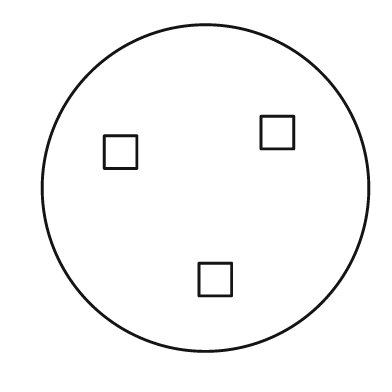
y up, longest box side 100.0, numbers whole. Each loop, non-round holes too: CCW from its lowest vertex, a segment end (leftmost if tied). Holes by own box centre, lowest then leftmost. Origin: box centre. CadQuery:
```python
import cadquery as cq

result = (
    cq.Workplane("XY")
    .moveTo(0.0, 0.0)
    .circle(50.0)
    .moveTo(-2.0, -33.0)
    .lineTo(8.0, -33.0)
    .lineTo(8.0, -23.0)
    .lineTo(-2.0, -23.0)
    .close()
    .moveTo(-31.0, 6.0)
    .lineTo(-21.0, 6.0)
    .lineTo(-21.0, 16.0)
    .lineTo(-31.0, 16.0)
    .close()
    .moveTo(17.0, 12.0)
    .lineTo(27.0, 12.0)
    .lineTo(27.0, 22.0)
    .lineTo(17.0, 22.0)
    .close()
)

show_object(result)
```